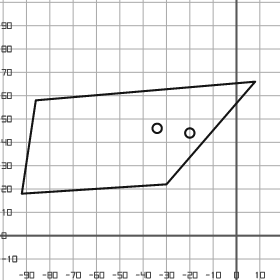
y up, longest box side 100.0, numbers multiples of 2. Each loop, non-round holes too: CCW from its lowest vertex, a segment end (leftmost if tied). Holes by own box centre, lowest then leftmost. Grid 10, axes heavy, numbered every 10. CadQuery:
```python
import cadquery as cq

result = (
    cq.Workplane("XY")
    .moveTo(-92.0, 18.0)
    .lineTo(-30.0, 22.0)
    .lineTo(8.0, 66.0)
    .lineTo(-86.0, 58.0)
    .close()
    .moveTo(-20.0, 44.0)
    .circle(2.0)
    .moveTo(-34.0, 46.0)
    .circle(2.0)
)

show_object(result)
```